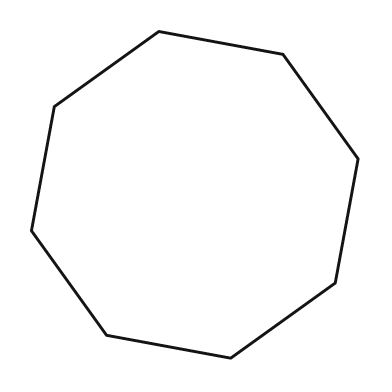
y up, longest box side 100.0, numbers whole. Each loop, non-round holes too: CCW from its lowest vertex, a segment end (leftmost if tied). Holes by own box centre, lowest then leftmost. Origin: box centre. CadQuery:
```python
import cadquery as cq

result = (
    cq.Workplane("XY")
    .moveTo(11.0, -50.0)
    .lineTo(43.0, -27.0)
    .lineTo(50.0, 11.0)
    .lineTo(27.0, 43.0)
    .lineTo(-11.0, 50.0)
    .lineTo(-43.0, 27.0)
    .lineTo(-50.0, -11.0)
    .lineTo(-27.0, -43.0)
    .close()
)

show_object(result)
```